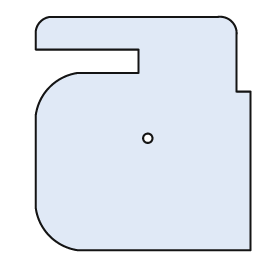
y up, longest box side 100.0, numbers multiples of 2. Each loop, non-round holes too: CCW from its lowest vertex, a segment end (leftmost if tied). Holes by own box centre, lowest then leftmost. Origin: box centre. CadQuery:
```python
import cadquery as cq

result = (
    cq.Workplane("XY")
    .moveTo(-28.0, -50.0)
    .lineTo(46.0, -50.0)
    .lineTo(46.0, 18.0)
    .lineTo(40.0, 18.0)
    .lineTo(40.0, 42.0)
    .threePointArc((38.0, 48.0), (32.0, 50.0))
    .lineTo(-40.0, 50.0)
    .threePointArc((-44.0, 48.0), (-46.0, 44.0))
    .lineTo(-46.0, 36.0)
    .lineTo(-2.0, 36.0)
    .lineTo(-2.0, 26.0)
    .lineTo(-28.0, 26.0)
    .threePointArc((-40.0, 20.0), (-46.0, 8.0))
    .lineTo(-46.0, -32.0)
    .threePointArc((-40.0, -44.0), (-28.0, -50.0))
    .close()
    .moveTo(2.0, -2.0)
    .circle(2.0)
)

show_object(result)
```